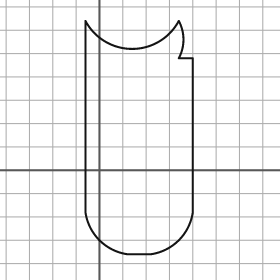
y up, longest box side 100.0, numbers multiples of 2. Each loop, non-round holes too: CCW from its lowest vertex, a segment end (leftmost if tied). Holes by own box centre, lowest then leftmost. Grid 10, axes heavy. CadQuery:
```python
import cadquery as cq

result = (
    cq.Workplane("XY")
    .moveTo(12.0, -36.0)
    .lineTo(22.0, -36.0)
    .threePointArc((34.0, -30.0), (40.0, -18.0))
    .lineTo(40.0, 48.0)
    .lineTo(34.0, 48.0)
    .threePointArc((36.0, 56.0), (34.0, 64.0))
    .threePointArc((14.0, 52.0), (-6.0, 64.0))
    .lineTo(-6.0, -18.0)
    .threePointArc((0.0, -30.0), (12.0, -36.0))
    .close()
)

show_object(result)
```